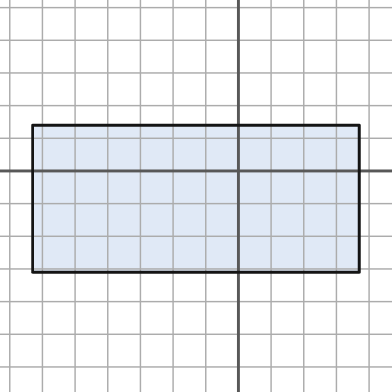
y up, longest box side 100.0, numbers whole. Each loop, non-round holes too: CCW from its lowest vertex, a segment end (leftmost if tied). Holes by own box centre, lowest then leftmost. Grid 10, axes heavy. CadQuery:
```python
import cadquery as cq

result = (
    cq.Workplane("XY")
    .moveTo(-63.0, -31.0)
    .lineTo(37.0, -31.0)
    .lineTo(37.0, 14.0)
    .lineTo(-63.0, 14.0)
    .close()
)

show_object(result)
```